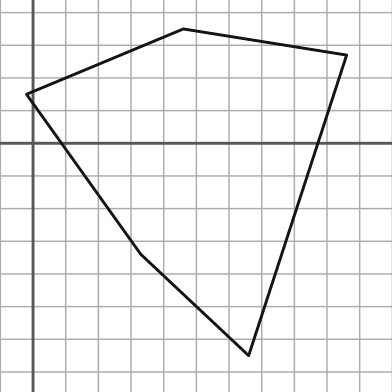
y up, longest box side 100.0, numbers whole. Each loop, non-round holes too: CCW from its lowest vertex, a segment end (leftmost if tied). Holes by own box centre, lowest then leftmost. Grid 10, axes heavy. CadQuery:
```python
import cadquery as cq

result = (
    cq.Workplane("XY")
    .moveTo(66.0, -65.0)
    .lineTo(96.0, 27.0)
    .lineTo(46.0, 35.0)
    .lineTo(-2.0, 15.0)
    .lineTo(33.0, -34.0)
    .close()
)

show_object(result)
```